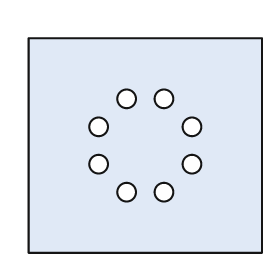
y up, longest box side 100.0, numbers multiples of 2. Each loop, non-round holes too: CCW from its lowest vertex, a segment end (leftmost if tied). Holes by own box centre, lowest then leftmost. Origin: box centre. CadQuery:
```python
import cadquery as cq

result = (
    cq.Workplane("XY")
    .moveTo(-50.0, -46.0)
    .lineTo(50.0, -46.0)
    .lineTo(50.0, 46.0)
    .lineTo(-50.0, 46.0)
    .close()
    .moveTo(-8.0, -20.0)
    .circle(4.0)
    .moveTo(8.0, -20.0)
    .circle(4.0)
    .moveTo(-20.0, -8.0)
    .circle(4.0)
    .moveTo(20.0, -8.0)
    .circle(4.0)
    .moveTo(-20.0, 8.0)
    .circle(4.0)
    .moveTo(20.0, 8.0)
    .circle(4.0)
    .moveTo(-8.0, 20.0)
    .circle(4.0)
    .moveTo(8.0, 20.0)
    .circle(4.0)
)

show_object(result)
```